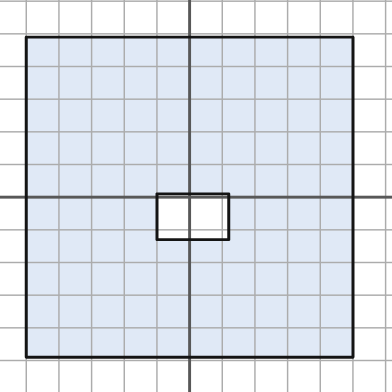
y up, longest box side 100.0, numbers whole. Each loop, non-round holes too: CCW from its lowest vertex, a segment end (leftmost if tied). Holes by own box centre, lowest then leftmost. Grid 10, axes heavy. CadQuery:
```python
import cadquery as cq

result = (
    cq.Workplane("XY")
    .moveTo(-50.0, -49.0)
    .lineTo(50.0, -49.0)
    .lineTo(50.0, 49.0)
    .lineTo(-50.0, 49.0)
    .close()
    .moveTo(-10.0, -13.0)
    .lineTo(12.0, -13.0)
    .lineTo(12.0, 1.0)
    .lineTo(-10.0, 1.0)
    .close()
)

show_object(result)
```